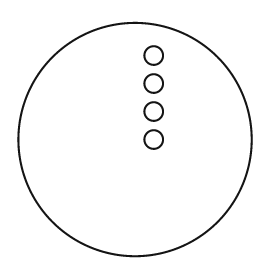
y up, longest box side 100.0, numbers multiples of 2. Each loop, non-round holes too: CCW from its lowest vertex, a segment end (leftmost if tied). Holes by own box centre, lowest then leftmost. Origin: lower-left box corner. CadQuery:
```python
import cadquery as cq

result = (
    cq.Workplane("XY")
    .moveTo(50.0, 50.0)
    .circle(50.0)
    .moveTo(58.0, 50.0)
    .circle(4.0)
    .moveTo(58.0, 62.0)
    .circle(4.0)
    .moveTo(58.0, 74.0)
    .circle(4.0)
    .moveTo(58.0, 86.0)
    .circle(4.0)
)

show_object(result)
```